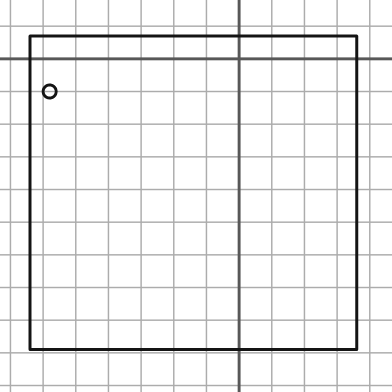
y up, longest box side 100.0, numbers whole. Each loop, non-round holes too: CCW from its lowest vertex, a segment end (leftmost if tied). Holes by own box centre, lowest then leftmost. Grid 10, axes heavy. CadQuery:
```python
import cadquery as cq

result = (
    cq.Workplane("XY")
    .moveTo(-64.0, -89.0)
    .lineTo(36.0, -89.0)
    .lineTo(36.0, 7.0)
    .lineTo(-64.0, 7.0)
    .close()
    .moveTo(-58.0, -10.0)
    .circle(2.0)
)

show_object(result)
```